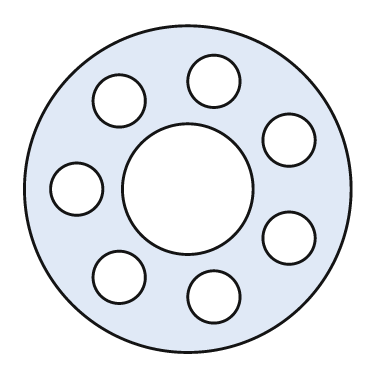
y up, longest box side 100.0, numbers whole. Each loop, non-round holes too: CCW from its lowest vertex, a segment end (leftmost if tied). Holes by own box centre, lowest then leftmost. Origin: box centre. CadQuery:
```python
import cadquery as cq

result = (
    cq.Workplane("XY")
    .moveTo(0.0, 0.0)
    .circle(50.0)
    .moveTo(8.0, -33.0)
    .circle(8.0)
    .moveTo(-21.0, -27.0)
    .circle(8.0)
    .moveTo(31.0, -15.0)
    .circle(8.0)
    .moveTo(-34.0, 0.0)
    .circle(8.0)
    .moveTo(0.0, 0.0)
    .circle(20.0)
    .moveTo(31.0, 15.0)
    .circle(8.0)
    .moveTo(-21.0, 27.0)
    .circle(8.0)
    .moveTo(8.0, 33.0)
    .circle(8.0)
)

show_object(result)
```